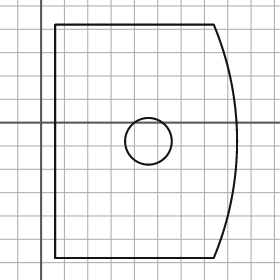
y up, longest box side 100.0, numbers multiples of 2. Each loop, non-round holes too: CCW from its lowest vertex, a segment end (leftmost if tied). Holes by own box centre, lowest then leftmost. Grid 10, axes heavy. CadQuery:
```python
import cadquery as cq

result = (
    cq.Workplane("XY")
    .moveTo(6.0, -58.0)
    .lineTo(74.0, -58.0)
    .threePointArc((84.0, -8.0), (74.0, 42.0))
    .lineTo(6.0, 42.0)
    .close()
    .moveTo(46.0, -8.0)
    .circle(10.0)
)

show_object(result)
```